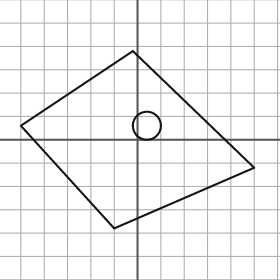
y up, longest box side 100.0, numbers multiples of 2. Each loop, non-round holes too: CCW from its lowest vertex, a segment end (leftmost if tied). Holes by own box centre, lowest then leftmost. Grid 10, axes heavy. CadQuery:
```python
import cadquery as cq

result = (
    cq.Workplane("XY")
    .moveTo(-10.0, -38.0)
    .lineTo(50.0, -12.0)
    .lineTo(-2.0, 38.0)
    .lineTo(-50.0, 6.0)
    .close()
    .moveTo(4.0, 6.0)
    .circle(6.0)
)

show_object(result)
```